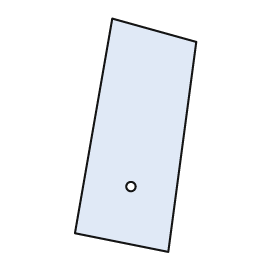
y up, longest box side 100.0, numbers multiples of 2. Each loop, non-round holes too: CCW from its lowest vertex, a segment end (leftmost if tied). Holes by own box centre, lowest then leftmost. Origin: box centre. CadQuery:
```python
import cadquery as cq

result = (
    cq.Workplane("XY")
    .moveTo(14.0, -50.0)
    .lineTo(26.0, 40.0)
    .lineTo(-10.0, 50.0)
    .lineTo(-26.0, -42.0)
    .close()
    .moveTo(-2.0, -22.0)
    .circle(2.0)
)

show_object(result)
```